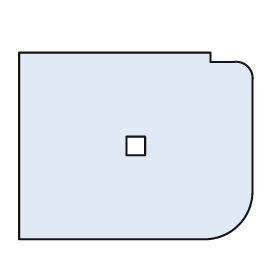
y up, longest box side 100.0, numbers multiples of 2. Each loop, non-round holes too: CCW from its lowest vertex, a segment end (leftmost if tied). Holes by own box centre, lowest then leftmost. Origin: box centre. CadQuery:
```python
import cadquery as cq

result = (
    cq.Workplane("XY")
    .moveTo(-50.0, -40.0)
    .lineTo(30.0, -40.0)
    .threePointArc((44.0, -34.0), (50.0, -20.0))
    .lineTo(50.0, 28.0)
    .threePointArc((48.0, 34.0), (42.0, 36.0))
    .lineTo(32.0, 36.0)
    .lineTo(32.0, 40.0)
    .lineTo(-50.0, 40.0)
    .close()
    .moveTo(-4.0, -4.0)
    .lineTo(4.0, -4.0)
    .lineTo(4.0, 4.0)
    .lineTo(-4.0, 4.0)
    .close()
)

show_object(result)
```